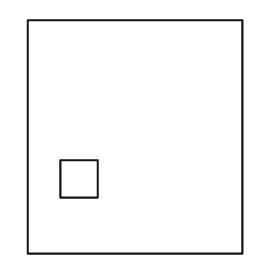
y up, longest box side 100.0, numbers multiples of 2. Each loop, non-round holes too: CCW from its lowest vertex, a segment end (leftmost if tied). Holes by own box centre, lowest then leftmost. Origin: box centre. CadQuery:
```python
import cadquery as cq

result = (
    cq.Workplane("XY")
    .moveTo(-46.0, -50.0)
    .lineTo(46.0, -50.0)
    .lineTo(46.0, 50.0)
    .lineTo(-46.0, 50.0)
    .close()
    .moveTo(-32.0, -26.0)
    .lineTo(-16.0, -26.0)
    .lineTo(-16.0, -10.0)
    .lineTo(-32.0, -10.0)
    .close()
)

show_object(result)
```